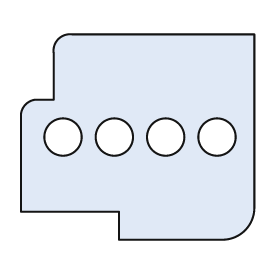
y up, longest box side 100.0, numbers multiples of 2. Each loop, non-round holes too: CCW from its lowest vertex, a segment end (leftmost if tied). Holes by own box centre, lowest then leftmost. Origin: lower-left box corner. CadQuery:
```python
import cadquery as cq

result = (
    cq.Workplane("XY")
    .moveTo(42.0, 0.0)
    .lineTo(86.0, 0.0)
    .threePointArc((96.0, 4.0), (100.0, 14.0))
    .lineTo(100.0, 88.0)
    .lineTo(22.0, 88.0)
    .threePointArc((16.0, 86.0), (14.0, 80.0))
    .lineTo(14.0, 60.0)
    .lineTo(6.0, 60.0)
    .threePointArc((2.0, 58.0), (0.0, 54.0))
    .lineTo(0.0, 12.0)
    .lineTo(42.0, 12.0)
    .close()
    .moveTo(18.0, 44.0)
    .circle(8.0)
    .moveTo(40.0, 44.0)
    .circle(8.0)
    .moveTo(62.0, 44.0)
    .circle(8.0)
    .moveTo(84.0, 44.0)
    .circle(8.0)
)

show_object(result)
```